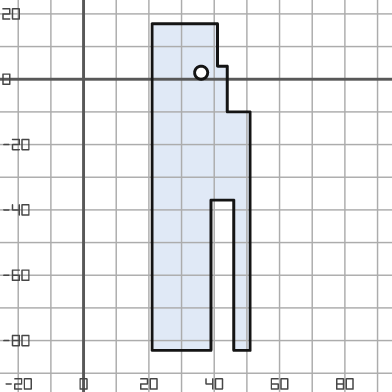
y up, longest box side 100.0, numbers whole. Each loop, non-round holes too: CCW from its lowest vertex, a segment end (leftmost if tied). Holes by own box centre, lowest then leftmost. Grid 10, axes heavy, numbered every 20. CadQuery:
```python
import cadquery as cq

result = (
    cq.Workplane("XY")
    .moveTo(21.0, -83.0)
    .lineTo(39.0, -83.0)
    .lineTo(39.0, -37.0)
    .lineTo(46.0, -37.0)
    .lineTo(46.0, -83.0)
    .lineTo(51.0, -83.0)
    .lineTo(51.0, -10.0)
    .lineTo(44.0, -10.0)
    .lineTo(44.0, 4.0)
    .lineTo(41.0, 4.0)
    .lineTo(41.0, 17.0)
    .lineTo(21.0, 17.0)
    .close()
    .moveTo(36.0, 2.0)
    .circle(2.0)
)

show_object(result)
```